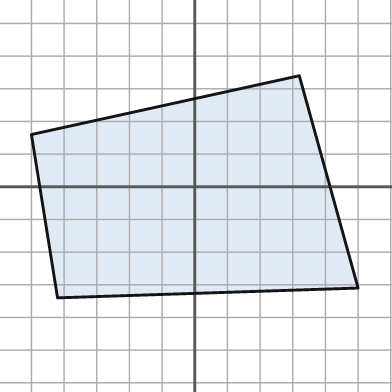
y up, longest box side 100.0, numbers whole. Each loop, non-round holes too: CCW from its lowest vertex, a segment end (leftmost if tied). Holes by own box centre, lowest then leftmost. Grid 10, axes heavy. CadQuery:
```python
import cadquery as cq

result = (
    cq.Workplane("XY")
    .moveTo(-42.0, -34.0)
    .lineTo(50.0, -31.0)
    .lineTo(32.0, 34.0)
    .lineTo(-50.0, 16.0)
    .close()
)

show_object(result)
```